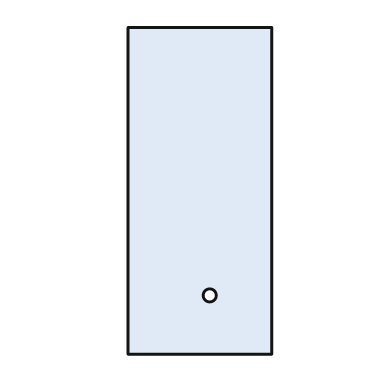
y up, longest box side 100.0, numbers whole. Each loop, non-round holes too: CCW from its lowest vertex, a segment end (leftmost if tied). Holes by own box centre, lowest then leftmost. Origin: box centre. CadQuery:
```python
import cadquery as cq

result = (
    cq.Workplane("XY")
    .moveTo(-22.0, -50.0)
    .lineTo(22.0, -50.0)
    .lineTo(22.0, 50.0)
    .lineTo(-22.0, 50.0)
    .close()
    .moveTo(3.0, -32.0)
    .circle(2.0)
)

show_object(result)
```